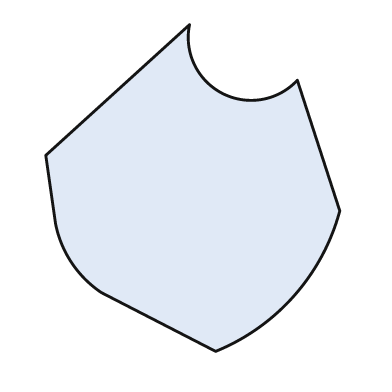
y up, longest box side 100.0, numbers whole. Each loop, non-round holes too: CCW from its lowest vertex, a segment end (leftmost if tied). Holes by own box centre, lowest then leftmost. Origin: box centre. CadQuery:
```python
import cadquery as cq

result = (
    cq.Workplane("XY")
    .moveTo(7.0, -50.0)
    .threePointArc((31.0, -33.0), (45.0, -7.0))
    .lineTo(32.0, 33.0)
    .threePointArc((9.0, 29.0), (-1.0, 50.0))
    .lineTo(-45.0, 10.0)
    .lineTo(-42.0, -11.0)
    .threePointArc((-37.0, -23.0), (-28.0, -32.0))
    .close()
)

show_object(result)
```